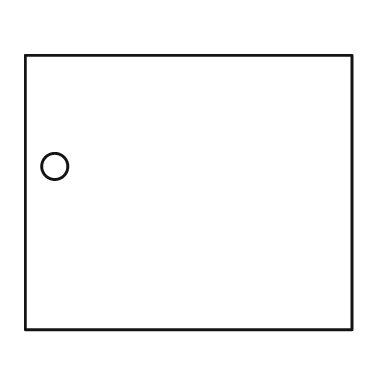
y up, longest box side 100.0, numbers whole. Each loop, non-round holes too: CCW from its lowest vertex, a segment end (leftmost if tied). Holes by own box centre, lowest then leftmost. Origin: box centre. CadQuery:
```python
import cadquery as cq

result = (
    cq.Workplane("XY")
    .moveTo(-50.0, -42.0)
    .lineTo(50.0, -42.0)
    .lineTo(50.0, 42.0)
    .lineTo(-50.0, 42.0)
    .close()
    .moveTo(-41.0, 8.0)
    .circle(4.0)
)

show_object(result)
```